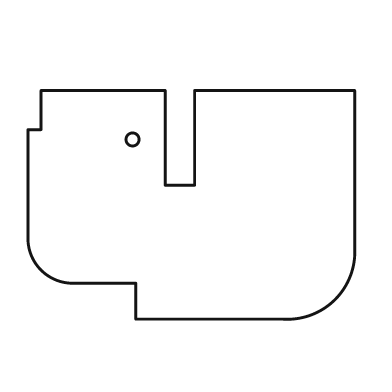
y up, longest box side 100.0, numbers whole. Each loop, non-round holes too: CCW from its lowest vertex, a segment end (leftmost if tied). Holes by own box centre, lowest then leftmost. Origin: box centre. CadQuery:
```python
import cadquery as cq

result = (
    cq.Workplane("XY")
    .moveTo(-17.0, -35.0)
    .lineTo(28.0, -35.0)
    .threePointArc((44.0, -29.0), (50.0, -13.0))
    .lineTo(50.0, 35.0)
    .lineTo(1.0, 35.0)
    .lineTo(1.0, 6.0)
    .lineTo(-8.0, 6.0)
    .lineTo(-8.0, 35.0)
    .lineTo(-46.0, 35.0)
    .lineTo(-46.0, 23.0)
    .lineTo(-50.0, 23.0)
    .lineTo(-50.0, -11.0)
    .threePointArc((-46.0, -20.0), (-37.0, -24.0))
    .lineTo(-17.0, -24.0)
    .close()
    .moveTo(-18.0, 20.0)
    .circle(2.0)
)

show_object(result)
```